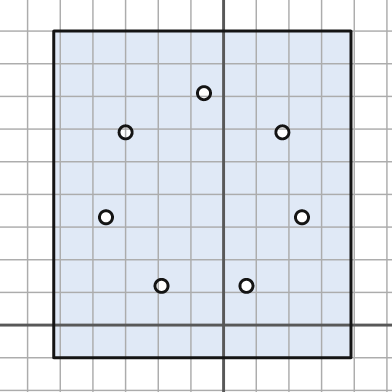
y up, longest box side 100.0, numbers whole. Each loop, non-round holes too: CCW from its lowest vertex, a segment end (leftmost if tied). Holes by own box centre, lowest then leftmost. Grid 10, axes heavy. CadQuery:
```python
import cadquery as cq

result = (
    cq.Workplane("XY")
    .moveTo(-52.0, -10.0)
    .lineTo(39.0, -10.0)
    .lineTo(39.0, 90.0)
    .lineTo(-52.0, 90.0)
    .close()
    .moveTo(-19.0, 12.0)
    .circle(2.0)
    .moveTo(7.0, 12.0)
    .circle(2.0)
    .moveTo(-36.0, 33.0)
    .circle(2.0)
    .moveTo(24.0, 33.0)
    .circle(2.0)
    .moveTo(-30.0, 59.0)
    .circle(2.0)
    .moveTo(18.0, 59.0)
    .circle(2.0)
    .moveTo(-6.0, 71.0)
    .circle(2.0)
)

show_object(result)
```